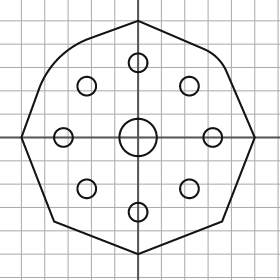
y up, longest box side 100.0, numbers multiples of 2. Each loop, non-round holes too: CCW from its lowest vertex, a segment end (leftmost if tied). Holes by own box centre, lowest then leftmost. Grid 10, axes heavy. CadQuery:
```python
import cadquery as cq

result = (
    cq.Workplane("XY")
    .moveTo(0.0, -50.0)
    .lineTo(36.0, -36.0)
    .lineTo(50.0, 0.0)
    .lineTo(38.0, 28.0)
    .threePointArc((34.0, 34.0), (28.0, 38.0))
    .lineTo(0.0, 50.0)
    .lineTo(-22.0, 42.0)
    .threePointArc((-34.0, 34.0), (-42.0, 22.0))
    .lineTo(-50.0, 0.0)
    .lineTo(-36.0, -36.0)
    .close()
    .moveTo(0.0, -32.0)
    .circle(4.0)
    .moveTo(-22.0, -22.0)
    .circle(4.0)
    .moveTo(22.0, -22.0)
    .circle(4.0)
    .moveTo(-32.0, 0.0)
    .circle(4.0)
    .moveTo(0.0, 0.0)
    .circle(8.0)
    .moveTo(32.0, 0.0)
    .circle(4.0)
    .moveTo(-22.0, 22.0)
    .circle(4.0)
    .moveTo(22.0, 22.0)
    .circle(4.0)
    .moveTo(0.0, 32.0)
    .circle(4.0)
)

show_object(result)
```